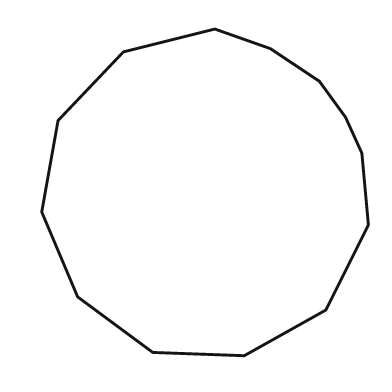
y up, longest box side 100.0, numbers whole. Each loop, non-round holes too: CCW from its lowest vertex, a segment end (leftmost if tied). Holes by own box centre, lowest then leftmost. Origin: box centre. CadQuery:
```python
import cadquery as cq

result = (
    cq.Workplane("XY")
    .moveTo(12.0, -50.0)
    .lineTo(37.0, -36.0)
    .lineTo(50.0, -10.0)
    .lineTo(48.0, 12.0)
    .lineTo(43.0, 23.0)
    .lineTo(35.0, 34.0)
    .lineTo(20.0, 44.0)
    .lineTo(3.0, 50.0)
    .lineTo(-25.0, 43.0)
    .lineTo(-45.0, 22.0)
    .lineTo(-50.0, -6.0)
    .lineTo(-39.0, -32.0)
    .lineTo(-16.0, -49.0)
    .close()
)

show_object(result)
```